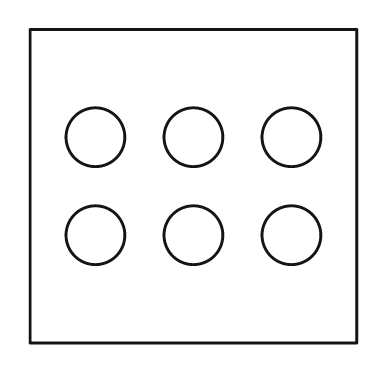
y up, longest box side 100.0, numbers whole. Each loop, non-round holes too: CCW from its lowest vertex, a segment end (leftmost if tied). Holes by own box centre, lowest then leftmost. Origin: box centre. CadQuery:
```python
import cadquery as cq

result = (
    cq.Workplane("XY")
    .moveTo(-50.0, -48.0)
    .lineTo(50.0, -48.0)
    .lineTo(50.0, 48.0)
    .lineTo(-50.0, 48.0)
    .close()
    .moveTo(-30.0, -15.0)
    .circle(9.0)
    .moveTo(0.0, -15.0)
    .circle(9.0)
    .moveTo(30.0, -15.0)
    .circle(9.0)
    .moveTo(-30.0, 15.0)
    .circle(9.0)
    .moveTo(0.0, 15.0)
    .circle(9.0)
    .moveTo(30.0, 15.0)
    .circle(9.0)
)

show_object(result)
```